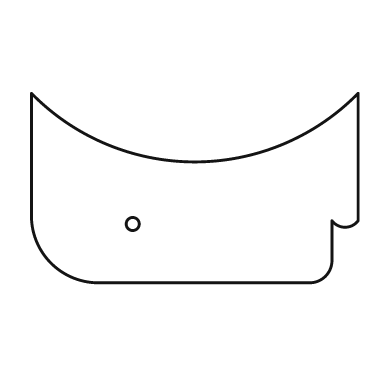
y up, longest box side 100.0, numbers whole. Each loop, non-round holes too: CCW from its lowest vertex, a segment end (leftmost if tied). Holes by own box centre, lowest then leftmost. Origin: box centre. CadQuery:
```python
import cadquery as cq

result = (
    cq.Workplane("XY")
    .moveTo(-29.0, -29.0)
    .lineTo(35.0, -29.0)
    .threePointArc((40.0, -27.0), (42.0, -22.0))
    .lineTo(42.0, -10.0)
    .threePointArc((46.0, -12.0), (50.0, -10.0))
    .lineTo(50.0, 29.0)
    .threePointArc((0.0, 8.0), (-50.0, 29.0))
    .lineTo(-50.0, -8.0)
    .threePointArc((-44.0, -23.0), (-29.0, -29.0))
    .close()
    .moveTo(-19.0, -11.0)
    .circle(2.0)
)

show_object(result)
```